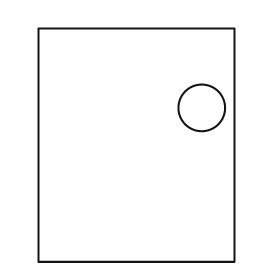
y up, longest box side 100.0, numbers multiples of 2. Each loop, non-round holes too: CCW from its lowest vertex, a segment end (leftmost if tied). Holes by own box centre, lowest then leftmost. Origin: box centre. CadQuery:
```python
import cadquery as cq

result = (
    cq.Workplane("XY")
    .moveTo(-42.0, -50.0)
    .lineTo(42.0, -50.0)
    .lineTo(42.0, 50.0)
    .lineTo(-42.0, 50.0)
    .close()
    .moveTo(28.0, 16.0)
    .circle(10.0)
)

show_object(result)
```